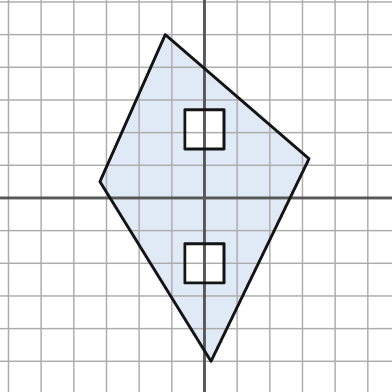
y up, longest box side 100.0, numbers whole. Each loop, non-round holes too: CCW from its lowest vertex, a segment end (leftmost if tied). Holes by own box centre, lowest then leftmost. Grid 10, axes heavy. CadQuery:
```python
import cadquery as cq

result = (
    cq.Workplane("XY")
    .moveTo(2.0, -50.0)
    .lineTo(32.0, 12.0)
    .lineTo(-12.0, 50.0)
    .lineTo(-32.0, 5.0)
    .close()
    .moveTo(-6.0, -26.0)
    .lineTo(6.0, -26.0)
    .lineTo(6.0, -14.0)
    .lineTo(-6.0, -14.0)
    .close()
    .moveTo(-6.0, 15.0)
    .lineTo(6.0, 15.0)
    .lineTo(6.0, 27.0)
    .lineTo(-6.0, 27.0)
    .close()
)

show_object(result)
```